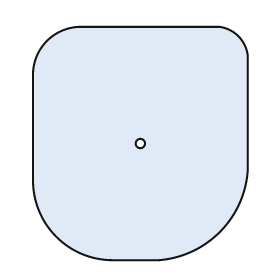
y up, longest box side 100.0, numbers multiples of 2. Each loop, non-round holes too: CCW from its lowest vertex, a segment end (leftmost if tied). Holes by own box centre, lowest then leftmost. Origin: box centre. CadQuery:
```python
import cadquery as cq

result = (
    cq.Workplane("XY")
    .moveTo(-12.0, -50.0)
    .lineTo(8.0, -50.0)
    .threePointArc((34.0, -38.0), (46.0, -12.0))
    .lineTo(46.0, 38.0)
    .threePointArc((42.0, 46.0), (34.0, 50.0))
    .lineTo(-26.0, 50.0)
    .threePointArc((-40.0, 44.0), (-46.0, 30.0))
    .lineTo(-46.0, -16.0)
    .threePointArc((-36.0, -40.0), (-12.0, -50.0))
    .close()
    .moveTo(0.0, 0.0)
    .circle(2.0)
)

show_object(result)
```